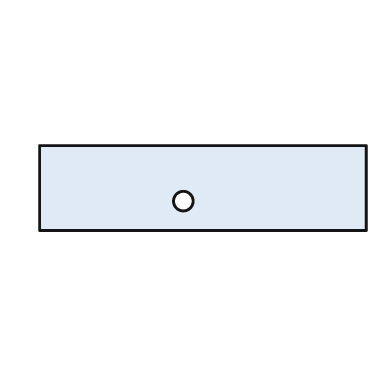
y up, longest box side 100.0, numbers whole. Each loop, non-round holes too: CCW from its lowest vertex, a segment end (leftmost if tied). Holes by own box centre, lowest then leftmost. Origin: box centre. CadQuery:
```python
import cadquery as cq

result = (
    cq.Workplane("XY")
    .moveTo(-50.0, -13.0)
    .lineTo(50.0, -13.0)
    .lineTo(50.0, 13.0)
    .lineTo(-50.0, 13.0)
    .close()
    .moveTo(-6.0, -4.0)
    .circle(3.0)
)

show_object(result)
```